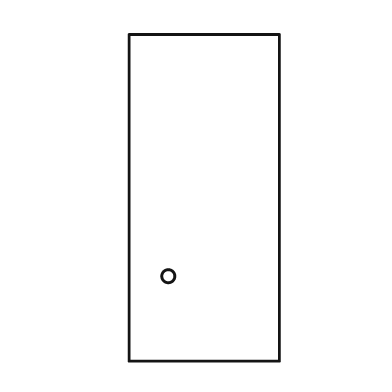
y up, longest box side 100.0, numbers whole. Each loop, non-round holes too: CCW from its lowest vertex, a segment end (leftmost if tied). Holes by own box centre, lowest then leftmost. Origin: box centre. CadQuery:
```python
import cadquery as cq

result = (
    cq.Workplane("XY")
    .moveTo(-23.0, -50.0)
    .lineTo(23.0, -50.0)
    .lineTo(23.0, 50.0)
    .lineTo(-23.0, 50.0)
    .close()
    .moveTo(-11.0, -24.0)
    .circle(2.0)
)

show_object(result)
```